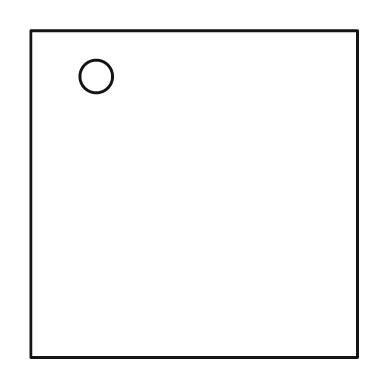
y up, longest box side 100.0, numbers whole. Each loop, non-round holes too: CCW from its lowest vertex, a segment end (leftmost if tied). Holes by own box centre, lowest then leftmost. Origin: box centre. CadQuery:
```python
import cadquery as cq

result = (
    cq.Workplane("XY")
    .moveTo(-50.0, -50.0)
    .lineTo(50.0, -50.0)
    .lineTo(50.0, 50.0)
    .lineTo(-50.0, 50.0)
    .close()
    .moveTo(-30.0, 36.0)
    .circle(5.0)
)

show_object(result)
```